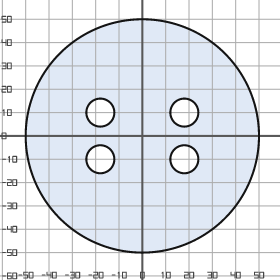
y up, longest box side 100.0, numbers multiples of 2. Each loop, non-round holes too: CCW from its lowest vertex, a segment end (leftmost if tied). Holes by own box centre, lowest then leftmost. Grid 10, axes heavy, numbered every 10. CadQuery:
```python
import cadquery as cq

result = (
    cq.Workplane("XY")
    .moveTo(0.0, 0.0)
    .circle(50.0)
    .moveTo(-18.0, -10.0)
    .circle(6.0)
    .moveTo(18.0, -10.0)
    .circle(6.0)
    .moveTo(-18.0, 10.0)
    .circle(6.0)
    .moveTo(18.0, 10.0)
    .circle(6.0)
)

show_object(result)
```